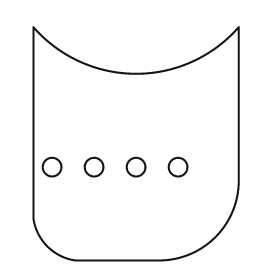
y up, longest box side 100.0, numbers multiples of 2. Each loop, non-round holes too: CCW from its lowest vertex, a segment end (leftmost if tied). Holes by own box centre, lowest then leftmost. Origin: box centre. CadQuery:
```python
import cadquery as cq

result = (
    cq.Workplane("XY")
    .moveTo(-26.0, -50.0)
    .lineTo(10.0, -50.0)
    .threePointArc((34.0, -40.0), (44.0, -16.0))
    .lineTo(44.0, 50.0)
    .threePointArc((0.0, 30.0), (-44.0, 50.0))
    .lineTo(-44.0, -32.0)
    .threePointArc((-38.0, -44.0), (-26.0, -50.0))
    .close()
    .moveTo(-36.0, -10.0)
    .circle(4.0)
    .moveTo(-18.0, -10.0)
    .circle(4.0)
    .moveTo(0.0, -10.0)
    .circle(4.0)
    .moveTo(18.0, -10.0)
    .circle(4.0)
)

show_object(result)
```